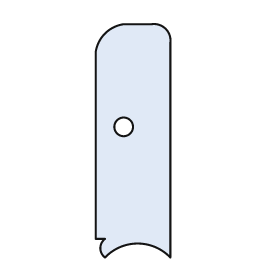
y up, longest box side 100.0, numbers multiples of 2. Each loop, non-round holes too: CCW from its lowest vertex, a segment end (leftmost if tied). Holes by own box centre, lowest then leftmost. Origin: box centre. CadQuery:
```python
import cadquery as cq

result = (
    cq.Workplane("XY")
    .moveTo(-12.0, -50.0)
    .threePointArc((2.0, -44.0), (16.0, -50.0))
    .lineTo(16.0, 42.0)
    .threePointArc((14.0, 48.0), (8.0, 50.0))
    .lineTo(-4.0, 50.0)
    .threePointArc((-12.0, 46.0), (-16.0, 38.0))
    .lineTo(-16.0, -42.0)
    .lineTo(-12.0, -42.0)
    .threePointArc((-14.0, -46.0), (-12.0, -50.0))
    .close()
    .moveTo(-4.0, 6.0)
    .circle(4.0)
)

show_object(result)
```